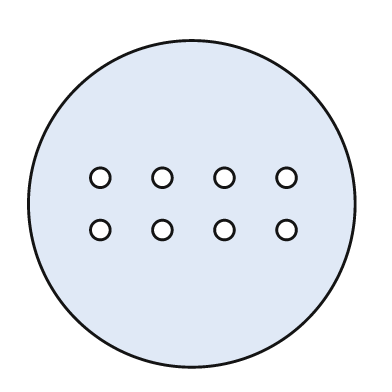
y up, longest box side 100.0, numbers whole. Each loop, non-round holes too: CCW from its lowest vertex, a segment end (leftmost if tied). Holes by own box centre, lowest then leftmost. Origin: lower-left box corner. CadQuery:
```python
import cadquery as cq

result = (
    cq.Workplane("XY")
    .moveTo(50.0, 50.0)
    .circle(50.0)
    .moveTo(22.0, 42.0)
    .circle(3.0)
    .moveTo(41.0, 42.0)
    .circle(3.0)
    .moveTo(60.0, 42.0)
    .circle(3.0)
    .moveTo(79.0, 42.0)
    .circle(3.0)
    .moveTo(22.0, 58.0)
    .circle(3.0)
    .moveTo(41.0, 58.0)
    .circle(3.0)
    .moveTo(60.0, 58.0)
    .circle(3.0)
    .moveTo(79.0, 58.0)
    .circle(3.0)
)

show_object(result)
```